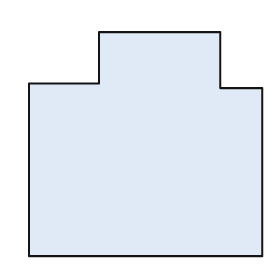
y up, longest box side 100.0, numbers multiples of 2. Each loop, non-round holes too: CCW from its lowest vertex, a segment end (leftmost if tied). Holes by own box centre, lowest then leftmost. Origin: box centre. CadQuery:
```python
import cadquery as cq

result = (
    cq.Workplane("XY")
    .moveTo(-50.0, -48.0)
    .lineTo(50.0, -48.0)
    .lineTo(50.0, 24.0)
    .lineTo(32.0, 24.0)
    .lineTo(32.0, 48.0)
    .lineTo(-20.0, 48.0)
    .lineTo(-20.0, 26.0)
    .lineTo(-50.0, 26.0)
    .close()
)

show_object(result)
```